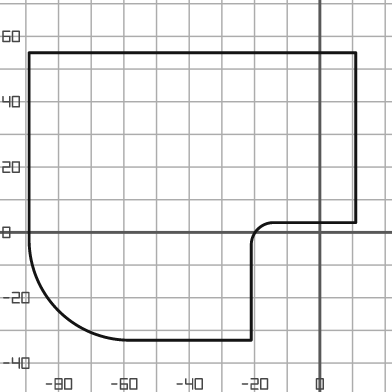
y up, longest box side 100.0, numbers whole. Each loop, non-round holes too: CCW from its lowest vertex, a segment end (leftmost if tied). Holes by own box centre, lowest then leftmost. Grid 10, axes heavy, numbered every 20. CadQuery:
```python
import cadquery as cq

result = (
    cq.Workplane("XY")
    .moveTo(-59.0, -33.0)
    .lineTo(-21.0, -33.0)
    .lineTo(-21.0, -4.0)
    .threePointArc((-19.0, 1.0), (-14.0, 3.0))
    .lineTo(11.0, 3.0)
    .lineTo(11.0, 55.0)
    .lineTo(-89.0, 55.0)
    .lineTo(-89.0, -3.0)
    .threePointArc((-80.0, -24.0), (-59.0, -33.0))
    .close()
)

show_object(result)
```